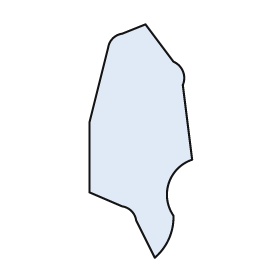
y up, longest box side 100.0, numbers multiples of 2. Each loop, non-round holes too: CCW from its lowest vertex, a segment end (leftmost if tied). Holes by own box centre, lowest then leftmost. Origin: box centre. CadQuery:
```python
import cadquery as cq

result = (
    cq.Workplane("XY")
    .moveTo(6.0, -50.0)
    .threePointArc((12.0, -42.0), (14.0, -32.0))
    .threePointArc((12.0, -18.0), (22.0, -8.0))
    .lineTo(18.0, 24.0)
    .threePointArc((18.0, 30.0), (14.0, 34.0))
    .lineTo(2.0, 50.0)
    .lineTo(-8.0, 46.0)
    .threePointArc((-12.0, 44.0), (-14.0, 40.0))
    .lineTo(-22.0, 8.0)
    .lineTo(-22.0, -22.0)
    .lineTo(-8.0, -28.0)
    .threePointArc((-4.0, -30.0), (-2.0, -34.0))
    .close()
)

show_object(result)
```